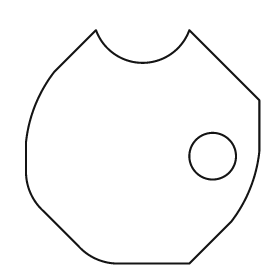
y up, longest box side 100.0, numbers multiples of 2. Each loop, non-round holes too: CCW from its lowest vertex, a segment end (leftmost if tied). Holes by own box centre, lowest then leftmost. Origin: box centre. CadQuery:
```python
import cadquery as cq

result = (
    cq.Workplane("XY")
    .moveTo(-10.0, -50.0)
    .lineTo(20.0, -50.0)
    .lineTo(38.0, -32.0)
    .threePointArc((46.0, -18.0), (50.0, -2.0))
    .lineTo(50.0, 20.0)
    .lineTo(20.0, 50.0)
    .threePointArc((0.0, 36.0), (-20.0, 50.0))
    .lineTo(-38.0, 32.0)
    .threePointArc((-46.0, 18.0), (-50.0, 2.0))
    .lineTo(-50.0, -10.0)
    .threePointArc((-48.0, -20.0), (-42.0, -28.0))
    .lineTo(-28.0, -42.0)
    .threePointArc((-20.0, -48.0), (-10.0, -50.0))
    .close()
    .moveTo(30.0, -4.0)
    .circle(10.0)
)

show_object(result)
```